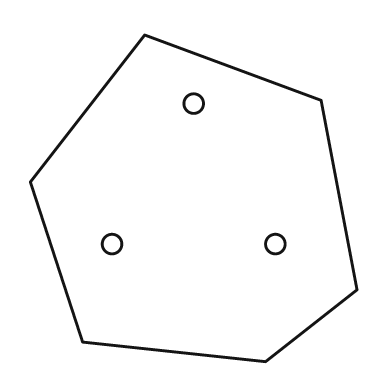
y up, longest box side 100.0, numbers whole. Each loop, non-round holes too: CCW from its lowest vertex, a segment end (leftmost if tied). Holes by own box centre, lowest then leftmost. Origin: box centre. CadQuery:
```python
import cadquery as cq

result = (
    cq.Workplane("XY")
    .moveTo(22.0, -50.0)
    .lineTo(50.0, -28.0)
    .lineTo(39.0, 30.0)
    .lineTo(-15.0, 50.0)
    .lineTo(-50.0, 5.0)
    .lineTo(-34.0, -44.0)
    .close()
    .moveTo(-25.0, -14.0)
    .circle(3.0)
    .moveTo(25.0, -14.0)
    .circle(3.0)
    .moveTo(0.0, 29.0)
    .circle(3.0)
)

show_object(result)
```